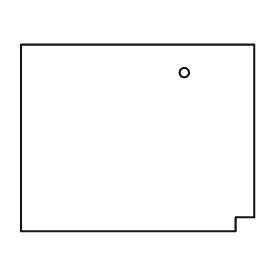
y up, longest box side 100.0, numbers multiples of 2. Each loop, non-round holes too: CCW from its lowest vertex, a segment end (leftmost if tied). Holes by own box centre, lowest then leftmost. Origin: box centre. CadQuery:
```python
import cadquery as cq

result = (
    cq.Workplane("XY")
    .moveTo(-50.0, -40.0)
    .lineTo(42.0, -40.0)
    .lineTo(42.0, -34.0)
    .lineTo(50.0, -34.0)
    .lineTo(50.0, 40.0)
    .lineTo(-50.0, 40.0)
    .close()
    .moveTo(20.0, 28.0)
    .circle(2.0)
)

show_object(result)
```